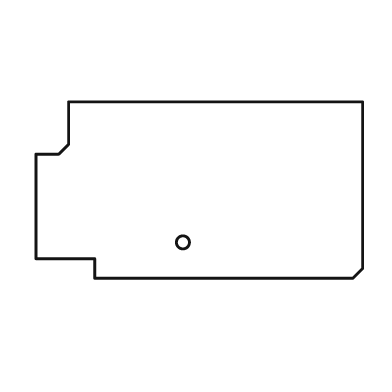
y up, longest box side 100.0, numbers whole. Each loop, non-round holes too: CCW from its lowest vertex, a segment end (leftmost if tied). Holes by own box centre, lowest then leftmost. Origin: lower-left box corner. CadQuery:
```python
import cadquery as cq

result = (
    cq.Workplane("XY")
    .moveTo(18.0, 0.0)
    .lineTo(97.0, 0.0)
    .lineTo(100.0, 3.0)
    .lineTo(100.0, 54.0)
    .lineTo(10.0, 54.0)
    .lineTo(10.0, 41.0)
    .lineTo(7.0, 38.0)
    .lineTo(0.0, 38.0)
    .lineTo(0.0, 6.0)
    .lineTo(18.0, 6.0)
    .close()
    .moveTo(45.0, 11.0)
    .circle(2.0)
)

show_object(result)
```